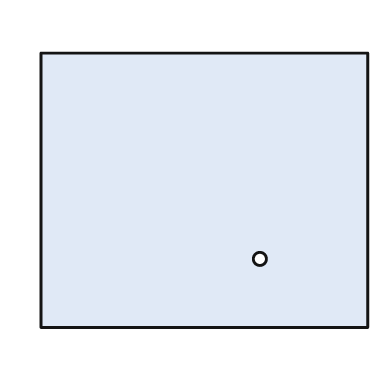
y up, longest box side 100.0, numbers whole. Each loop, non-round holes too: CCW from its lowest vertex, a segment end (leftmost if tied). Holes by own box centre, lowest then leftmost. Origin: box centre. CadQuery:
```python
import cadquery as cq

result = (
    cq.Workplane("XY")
    .moveTo(-50.0, -42.0)
    .lineTo(50.0, -42.0)
    .lineTo(50.0, 42.0)
    .lineTo(-50.0, 42.0)
    .close()
    .moveTo(17.0, -21.0)
    .circle(2.0)
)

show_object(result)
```